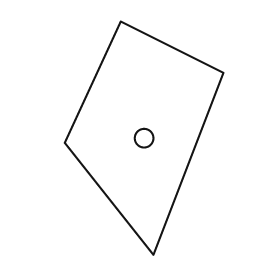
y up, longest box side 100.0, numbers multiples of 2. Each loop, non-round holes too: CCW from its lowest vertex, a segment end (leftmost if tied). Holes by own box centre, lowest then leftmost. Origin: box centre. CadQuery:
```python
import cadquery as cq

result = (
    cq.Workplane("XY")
    .moveTo(4.0, -50.0)
    .lineTo(34.0, 28.0)
    .lineTo(-10.0, 50.0)
    .lineTo(-34.0, -2.0)
    .close()
    .moveTo(0.0, 0.0)
    .circle(4.0)
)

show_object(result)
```